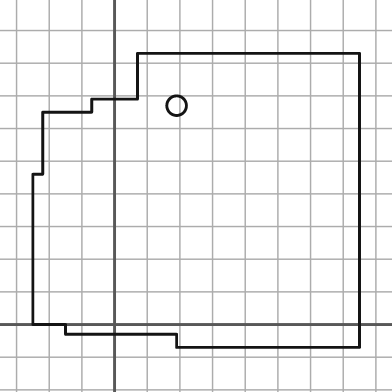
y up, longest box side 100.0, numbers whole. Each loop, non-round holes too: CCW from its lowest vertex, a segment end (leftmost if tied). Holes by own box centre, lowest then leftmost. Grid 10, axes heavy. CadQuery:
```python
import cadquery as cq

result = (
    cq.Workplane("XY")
    .moveTo(19.0, -7.0)
    .lineTo(75.0, -7.0)
    .lineTo(75.0, 83.0)
    .lineTo(7.0, 83.0)
    .lineTo(7.0, 69.0)
    .lineTo(-7.0, 69.0)
    .lineTo(-7.0, 65.0)
    .lineTo(-22.0, 65.0)
    .lineTo(-22.0, 46.0)
    .lineTo(-25.0, 46.0)
    .lineTo(-25.0, 0.0)
    .lineTo(-15.0, 0.0)
    .lineTo(-15.0, -3.0)
    .lineTo(19.0, -3.0)
    .close()
    .moveTo(19.0, 67.0)
    .circle(3.0)
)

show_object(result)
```